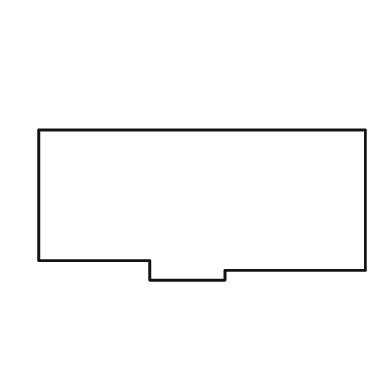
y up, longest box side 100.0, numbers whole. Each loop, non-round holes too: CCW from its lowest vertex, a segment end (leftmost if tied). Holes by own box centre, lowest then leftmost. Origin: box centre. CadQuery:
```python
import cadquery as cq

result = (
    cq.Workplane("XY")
    .moveTo(-16.0, -23.0)
    .lineTo(7.0, -23.0)
    .lineTo(7.0, -20.0)
    .lineTo(50.0, -20.0)
    .lineTo(50.0, 23.0)
    .lineTo(-50.0, 23.0)
    .lineTo(-50.0, -17.0)
    .lineTo(-16.0, -17.0)
    .close()
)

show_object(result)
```